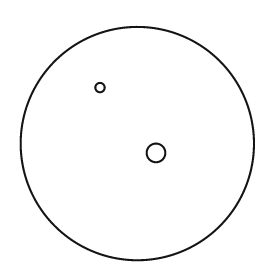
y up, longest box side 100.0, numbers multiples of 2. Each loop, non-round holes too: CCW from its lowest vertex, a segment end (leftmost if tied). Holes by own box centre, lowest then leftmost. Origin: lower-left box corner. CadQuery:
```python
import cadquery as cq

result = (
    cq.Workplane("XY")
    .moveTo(50.0, 50.0)
    .circle(50.0)
    .moveTo(58.0, 46.0)
    .circle(4.0)
    .moveTo(34.0, 74.0)
    .circle(2.0)
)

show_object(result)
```